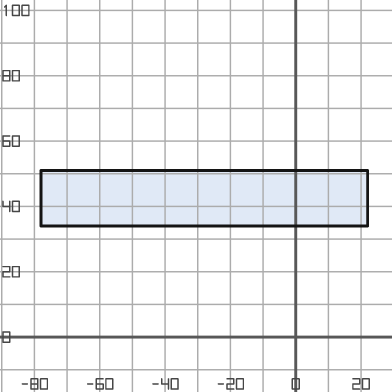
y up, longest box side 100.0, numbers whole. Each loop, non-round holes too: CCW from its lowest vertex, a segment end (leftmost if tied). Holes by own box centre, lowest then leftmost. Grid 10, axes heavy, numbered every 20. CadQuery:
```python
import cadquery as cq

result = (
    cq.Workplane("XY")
    .moveTo(-78.0, 34.0)
    .lineTo(22.0, 34.0)
    .lineTo(22.0, 51.0)
    .lineTo(-78.0, 51.0)
    .close()
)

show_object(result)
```